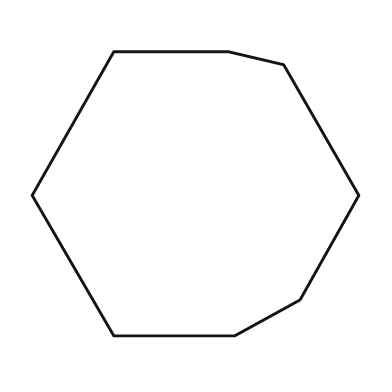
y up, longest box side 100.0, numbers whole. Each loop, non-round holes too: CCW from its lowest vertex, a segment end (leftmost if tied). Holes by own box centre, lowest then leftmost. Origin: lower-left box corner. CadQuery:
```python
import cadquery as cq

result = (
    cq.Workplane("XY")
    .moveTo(25.0, 0.0)
    .lineTo(62.0, 0.0)
    .lineTo(82.0, 11.0)
    .lineTo(100.0, 43.0)
    .lineTo(77.0, 83.0)
    .lineTo(60.0, 87.0)
    .lineTo(25.0, 87.0)
    .lineTo(0.0, 43.0)
    .close()
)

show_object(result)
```